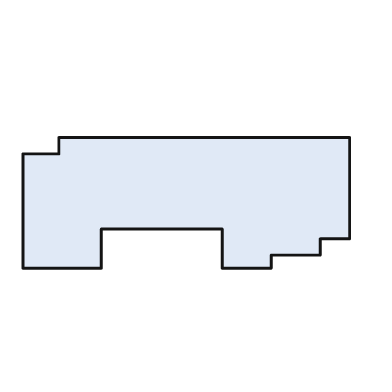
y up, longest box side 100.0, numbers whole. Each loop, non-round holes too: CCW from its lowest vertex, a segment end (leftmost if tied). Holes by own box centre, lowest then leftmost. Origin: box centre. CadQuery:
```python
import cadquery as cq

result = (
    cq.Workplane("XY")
    .moveTo(-50.0, -20.0)
    .lineTo(-26.0, -20.0)
    .lineTo(-26.0, -8.0)
    .lineTo(11.0, -8.0)
    .lineTo(11.0, -20.0)
    .lineTo(26.0, -20.0)
    .lineTo(26.0, -16.0)
    .lineTo(41.0, -16.0)
    .lineTo(41.0, -11.0)
    .lineTo(50.0, -11.0)
    .lineTo(50.0, 20.0)
    .lineTo(-39.0, 20.0)
    .lineTo(-39.0, 15.0)
    .lineTo(-50.0, 15.0)
    .close()
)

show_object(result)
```